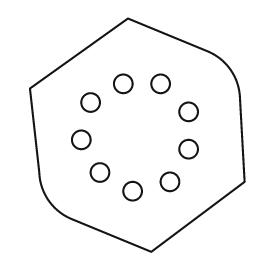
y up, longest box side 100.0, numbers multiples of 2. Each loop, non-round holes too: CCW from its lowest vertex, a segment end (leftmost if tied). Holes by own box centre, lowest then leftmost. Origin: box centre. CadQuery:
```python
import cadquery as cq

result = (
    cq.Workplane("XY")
    .moveTo(6.0, -50.0)
    .lineTo(46.0, -20.0)
    .lineTo(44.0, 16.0)
    .threePointArc((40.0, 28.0), (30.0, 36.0))
    .lineTo(-4.0, 50.0)
    .lineTo(-46.0, 20.0)
    .lineTo(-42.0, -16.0)
    .threePointArc((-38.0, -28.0), (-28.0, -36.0))
    .close()
    .moveTo(-2.0, -24.0)
    .circle(4.0)
    .moveTo(14.0, -20.0)
    .circle(4.0)
    .moveTo(-16.0, -16.0)
    .circle(4.0)
    .moveTo(22.0, -6.0)
    .circle(4.0)
    .moveTo(-24.0, -2.0)
    .circle(4.0)
    .moveTo(22.0, 10.0)
    .circle(4.0)
    .moveTo(-20.0, 14.0)
    .circle(4.0)
    .moveTo(-6.0, 22.0)
    .circle(4.0)
    .moveTo(10.0, 22.0)
    .circle(4.0)
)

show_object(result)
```